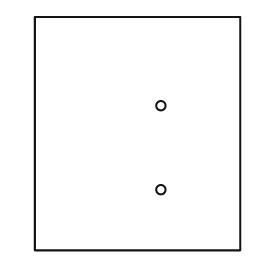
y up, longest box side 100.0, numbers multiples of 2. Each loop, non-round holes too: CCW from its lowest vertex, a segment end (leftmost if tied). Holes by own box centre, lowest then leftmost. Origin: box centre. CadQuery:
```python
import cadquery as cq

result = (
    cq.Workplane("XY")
    .moveTo(-44.0, -50.0)
    .lineTo(44.0, -50.0)
    .lineTo(44.0, 50.0)
    .lineTo(-44.0, 50.0)
    .close()
    .moveTo(10.0, -24.0)
    .circle(2.0)
    .moveTo(10.0, 12.0)
    .circle(2.0)
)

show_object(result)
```